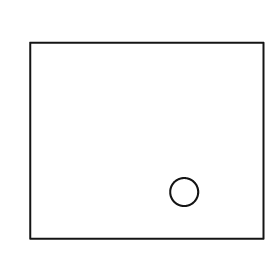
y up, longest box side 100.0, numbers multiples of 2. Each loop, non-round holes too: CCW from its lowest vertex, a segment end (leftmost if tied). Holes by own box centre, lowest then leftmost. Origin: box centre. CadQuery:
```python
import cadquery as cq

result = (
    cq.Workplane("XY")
    .moveTo(-50.0, -42.0)
    .lineTo(50.0, -42.0)
    .lineTo(50.0, 42.0)
    .lineTo(-50.0, 42.0)
    .close()
    .moveTo(16.0, -22.0)
    .circle(6.0)
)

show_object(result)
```